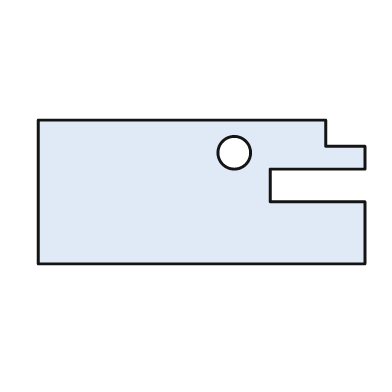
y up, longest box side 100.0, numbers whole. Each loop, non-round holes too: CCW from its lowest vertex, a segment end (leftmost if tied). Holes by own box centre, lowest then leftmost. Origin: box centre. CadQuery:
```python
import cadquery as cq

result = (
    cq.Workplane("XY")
    .moveTo(-50.0, -22.0)
    .lineTo(50.0, -22.0)
    .lineTo(50.0, -3.0)
    .lineTo(21.0, -3.0)
    .lineTo(21.0, 7.0)
    .lineTo(50.0, 7.0)
    .lineTo(50.0, 14.0)
    .lineTo(38.0, 14.0)
    .lineTo(38.0, 22.0)
    .lineTo(-50.0, 22.0)
    .close()
    .moveTo(10.0, 12.0)
    .circle(5.0)
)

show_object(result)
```